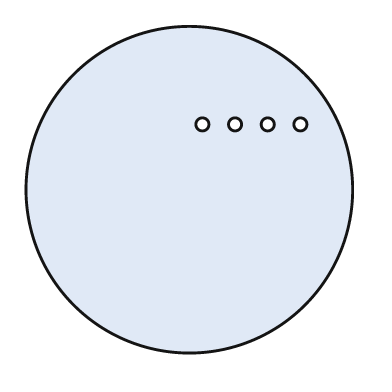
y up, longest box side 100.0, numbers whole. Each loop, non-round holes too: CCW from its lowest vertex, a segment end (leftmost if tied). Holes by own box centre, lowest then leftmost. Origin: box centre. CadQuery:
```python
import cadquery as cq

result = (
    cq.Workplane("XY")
    .moveTo(0.0, 0.0)
    .circle(50.0)
    .moveTo(4.0, 20.0)
    .circle(2.0)
    .moveTo(14.0, 20.0)
    .circle(2.0)
    .moveTo(24.0, 20.0)
    .circle(2.0)
    .moveTo(34.0, 20.0)
    .circle(2.0)
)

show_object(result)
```